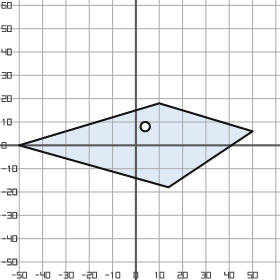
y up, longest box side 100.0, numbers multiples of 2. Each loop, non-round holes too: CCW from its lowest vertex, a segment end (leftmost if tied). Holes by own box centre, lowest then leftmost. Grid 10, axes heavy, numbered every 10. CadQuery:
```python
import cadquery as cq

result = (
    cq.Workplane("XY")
    .moveTo(14.0, -18.0)
    .lineTo(50.0, 6.0)
    .lineTo(10.0, 18.0)
    .lineTo(-50.0, 0.0)
    .close()
    .moveTo(4.0, 8.0)
    .circle(2.0)
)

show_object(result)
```